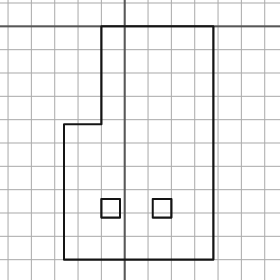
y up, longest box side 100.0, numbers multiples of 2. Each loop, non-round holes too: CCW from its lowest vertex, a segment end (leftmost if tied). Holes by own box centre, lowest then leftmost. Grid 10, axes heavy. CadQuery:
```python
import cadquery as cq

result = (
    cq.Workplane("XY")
    .moveTo(-26.0, -100.0)
    .lineTo(38.0, -100.0)
    .lineTo(38.0, 0.0)
    .lineTo(-10.0, 0.0)
    .lineTo(-10.0, -42.0)
    .lineTo(-26.0, -42.0)
    .close()
    .moveTo(-10.0, -82.0)
    .lineTo(-2.0, -82.0)
    .lineTo(-2.0, -74.0)
    .lineTo(-10.0, -74.0)
    .close()
    .moveTo(12.0, -82.0)
    .lineTo(20.0, -82.0)
    .lineTo(20.0, -74.0)
    .lineTo(12.0, -74.0)
    .close()
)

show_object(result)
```